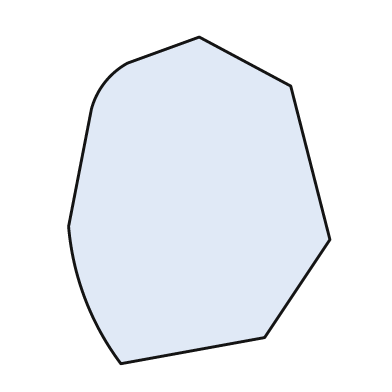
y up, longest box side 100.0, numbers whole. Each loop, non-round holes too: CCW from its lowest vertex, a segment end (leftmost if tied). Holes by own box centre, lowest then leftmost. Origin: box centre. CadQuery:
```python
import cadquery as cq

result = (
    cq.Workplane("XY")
    .moveTo(-24.0, -50.0)
    .lineTo(20.0, -42.0)
    .lineTo(40.0, -12.0)
    .lineTo(28.0, 35.0)
    .lineTo(0.0, 50.0)
    .lineTo(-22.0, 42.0)
    .threePointArc((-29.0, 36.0), (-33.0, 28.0))
    .lineTo(-40.0, -8.0)
    .threePointArc((-35.0, -30.0), (-24.0, -50.0))
    .close()
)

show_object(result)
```